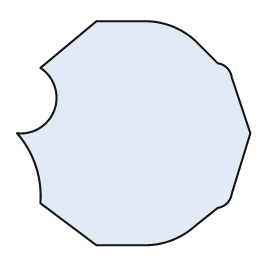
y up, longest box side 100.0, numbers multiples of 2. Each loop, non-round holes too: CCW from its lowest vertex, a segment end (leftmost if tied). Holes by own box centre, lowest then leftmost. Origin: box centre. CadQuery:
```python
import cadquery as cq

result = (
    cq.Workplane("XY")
    .moveTo(-16.0, -48.0)
    .lineTo(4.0, -48.0)
    .threePointArc((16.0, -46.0), (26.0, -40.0))
    .lineTo(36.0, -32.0)
    .threePointArc((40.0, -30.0), (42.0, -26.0))
    .lineTo(50.0, 0.0)
    .lineTo(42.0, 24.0)
    .threePointArc((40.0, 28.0), (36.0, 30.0))
    .lineTo(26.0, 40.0)
    .threePointArc((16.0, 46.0), (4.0, 48.0))
    .lineTo(-16.0, 48.0)
    .lineTo(-40.0, 28.0)
    .threePointArc((-34.0, 10.0), (-50.0, 0.0))
    .threePointArc((-42.0, -14.0), (-40.0, -30.0))
    .close()
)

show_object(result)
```